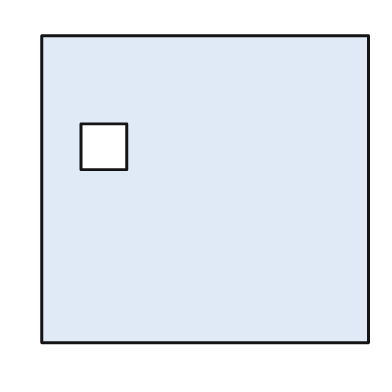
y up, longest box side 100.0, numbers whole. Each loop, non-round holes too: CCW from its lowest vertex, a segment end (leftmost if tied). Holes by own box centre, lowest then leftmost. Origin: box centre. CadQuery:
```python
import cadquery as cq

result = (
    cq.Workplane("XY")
    .moveTo(-50.0, -47.0)
    .lineTo(50.0, -47.0)
    .lineTo(50.0, 47.0)
    .lineTo(-50.0, 47.0)
    .close()
    .moveTo(-38.0, 6.0)
    .lineTo(-24.0, 6.0)
    .lineTo(-24.0, 20.0)
    .lineTo(-38.0, 20.0)
    .close()
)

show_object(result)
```